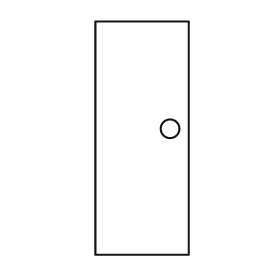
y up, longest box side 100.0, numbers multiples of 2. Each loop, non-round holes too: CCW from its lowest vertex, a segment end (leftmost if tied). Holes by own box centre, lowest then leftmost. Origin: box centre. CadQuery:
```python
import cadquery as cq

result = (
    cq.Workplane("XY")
    .moveTo(-20.0, -50.0)
    .lineTo(20.0, -50.0)
    .lineTo(20.0, 50.0)
    .lineTo(-20.0, 50.0)
    .close()
    .moveTo(12.0, 4.0)
    .circle(4.0)
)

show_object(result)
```